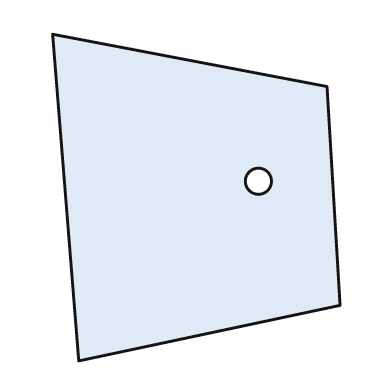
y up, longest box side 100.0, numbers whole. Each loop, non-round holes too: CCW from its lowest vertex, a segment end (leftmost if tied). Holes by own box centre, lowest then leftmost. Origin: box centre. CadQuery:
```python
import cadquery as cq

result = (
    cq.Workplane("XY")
    .moveTo(-36.0, -50.0)
    .lineTo(44.0, -33.0)
    .lineTo(40.0, 34.0)
    .lineTo(-44.0, 50.0)
    .close()
    .moveTo(19.0, 5.0)
    .circle(4.0)
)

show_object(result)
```